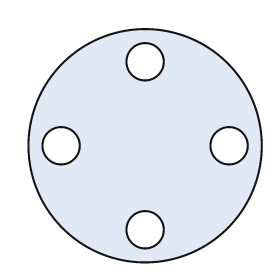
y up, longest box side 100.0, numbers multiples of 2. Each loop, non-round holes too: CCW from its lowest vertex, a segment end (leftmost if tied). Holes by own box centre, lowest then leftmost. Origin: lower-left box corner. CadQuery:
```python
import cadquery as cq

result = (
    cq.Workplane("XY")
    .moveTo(50.0, 50.0)
    .circle(50.0)
    .moveTo(50.0, 14.0)
    .circle(8.0)
    .moveTo(14.0, 50.0)
    .circle(8.0)
    .moveTo(86.0, 50.0)
    .circle(8.0)
    .moveTo(50.0, 86.0)
    .circle(8.0)
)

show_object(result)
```